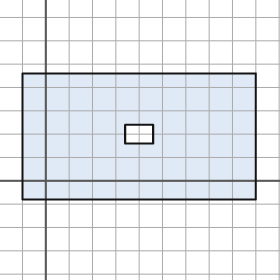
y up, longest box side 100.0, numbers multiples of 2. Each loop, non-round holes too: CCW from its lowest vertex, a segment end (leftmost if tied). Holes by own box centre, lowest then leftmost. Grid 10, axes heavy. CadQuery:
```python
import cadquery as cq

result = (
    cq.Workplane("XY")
    .moveTo(-10.0, -8.0)
    .lineTo(90.0, -8.0)
    .lineTo(90.0, 46.0)
    .lineTo(-10.0, 46.0)
    .close()
    .moveTo(34.0, 16.0)
    .lineTo(46.0, 16.0)
    .lineTo(46.0, 24.0)
    .lineTo(34.0, 24.0)
    .close()
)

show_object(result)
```